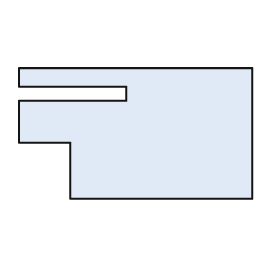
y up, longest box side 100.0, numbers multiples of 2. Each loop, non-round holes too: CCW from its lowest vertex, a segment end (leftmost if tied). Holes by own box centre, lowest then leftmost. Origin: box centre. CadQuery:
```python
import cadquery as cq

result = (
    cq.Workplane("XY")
    .moveTo(-28.0, -28.0)
    .lineTo(50.0, -28.0)
    .lineTo(50.0, 28.0)
    .lineTo(-50.0, 28.0)
    .lineTo(-50.0, 20.0)
    .lineTo(-4.0, 20.0)
    .lineTo(-4.0, 14.0)
    .lineTo(-50.0, 14.0)
    .lineTo(-50.0, -4.0)
    .lineTo(-28.0, -4.0)
    .close()
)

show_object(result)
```